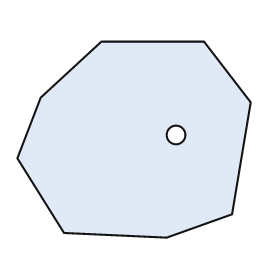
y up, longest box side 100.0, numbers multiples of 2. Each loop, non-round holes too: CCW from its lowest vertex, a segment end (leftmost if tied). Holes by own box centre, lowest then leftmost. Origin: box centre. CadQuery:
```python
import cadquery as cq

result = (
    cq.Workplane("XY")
    .moveTo(14.0, -42.0)
    .lineTo(42.0, -32.0)
    .lineTo(50.0, 16.0)
    .lineTo(30.0, 42.0)
    .lineTo(-14.0, 42.0)
    .lineTo(-40.0, 18.0)
    .lineTo(-50.0, -8.0)
    .lineTo(-30.0, -40.0)
    .close()
    .moveTo(18.0, 2.0)
    .circle(4.0)
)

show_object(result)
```